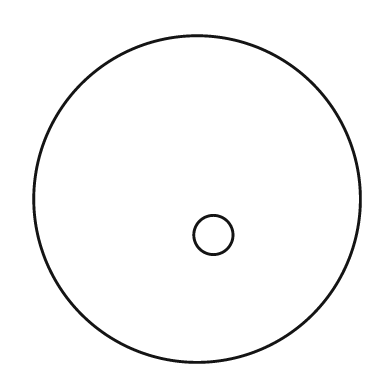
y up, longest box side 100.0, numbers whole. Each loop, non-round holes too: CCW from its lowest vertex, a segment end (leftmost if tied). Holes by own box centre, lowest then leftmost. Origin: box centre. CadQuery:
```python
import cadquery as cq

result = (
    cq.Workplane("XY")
    .moveTo(0.0, 0.0)
    .circle(50.0)
    .moveTo(5.0, -11.0)
    .circle(6.0)
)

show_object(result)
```